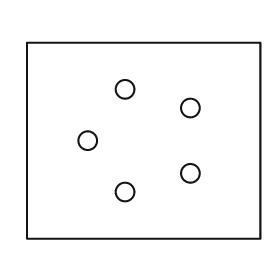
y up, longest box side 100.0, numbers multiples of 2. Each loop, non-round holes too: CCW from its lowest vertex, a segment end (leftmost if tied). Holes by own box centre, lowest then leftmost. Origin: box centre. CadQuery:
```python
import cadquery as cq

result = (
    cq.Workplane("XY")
    .moveTo(-50.0, -42.0)
    .lineTo(50.0, -42.0)
    .lineTo(50.0, 42.0)
    .lineTo(-50.0, 42.0)
    .close()
    .moveTo(-8.0, -22.0)
    .circle(4.0)
    .moveTo(20.0, -14.0)
    .circle(4.0)
    .moveTo(-24.0, 0.0)
    .circle(4.0)
    .moveTo(20.0, 14.0)
    .circle(4.0)
    .moveTo(-8.0, 22.0)
    .circle(4.0)
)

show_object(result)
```